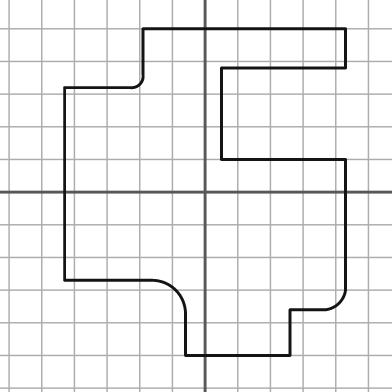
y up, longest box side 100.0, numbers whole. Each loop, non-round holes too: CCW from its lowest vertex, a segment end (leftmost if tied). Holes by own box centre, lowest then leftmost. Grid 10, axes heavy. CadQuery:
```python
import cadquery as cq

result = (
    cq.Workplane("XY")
    .moveTo(-6.0, -50.0)
    .lineTo(26.0, -50.0)
    .lineTo(26.0, -36.0)
    .lineTo(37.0, -36.0)
    .threePointArc((41.0, -34.0), (43.0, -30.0))
    .lineTo(43.0, 10.0)
    .lineTo(5.0, 10.0)
    .lineTo(5.0, 38.0)
    .lineTo(43.0, 38.0)
    .lineTo(43.0, 50.0)
    .lineTo(-19.0, 50.0)
    .lineTo(-19.0, 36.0)
    .threePointArc((-20.0, 33.0), (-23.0, 32.0))
    .lineTo(-43.0, 32.0)
    .lineTo(-43.0, -27.0)
    .lineTo(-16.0, -27.0)
    .threePointArc((-9.0, -30.0), (-6.0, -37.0))
    .close()
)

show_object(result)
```